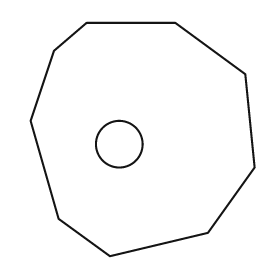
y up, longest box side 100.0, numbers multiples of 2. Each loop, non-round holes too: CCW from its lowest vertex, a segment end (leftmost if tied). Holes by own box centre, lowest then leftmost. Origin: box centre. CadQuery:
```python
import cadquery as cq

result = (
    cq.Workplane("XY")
    .moveTo(-14.0, -50.0)
    .lineTo(28.0, -40.0)
    .lineTo(48.0, -12.0)
    .lineTo(44.0, 28.0)
    .lineTo(14.0, 50.0)
    .lineTo(-24.0, 50.0)
    .lineTo(-38.0, 38.0)
    .lineTo(-48.0, 8.0)
    .lineTo(-36.0, -34.0)
    .close()
    .moveTo(-10.0, -2.0)
    .circle(10.0)
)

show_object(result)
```